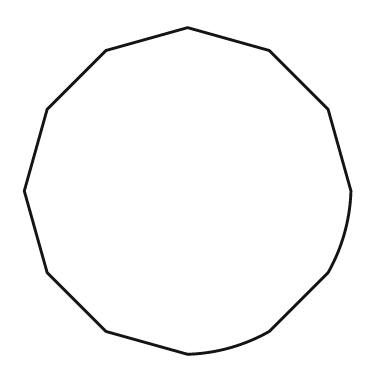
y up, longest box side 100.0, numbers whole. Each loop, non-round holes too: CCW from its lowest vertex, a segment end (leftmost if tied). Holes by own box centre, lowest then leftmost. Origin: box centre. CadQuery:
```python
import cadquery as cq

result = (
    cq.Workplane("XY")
    .moveTo(0.0, -50.0)
    .threePointArc((13.0, -48.0), (25.0, -43.0))
    .lineTo(43.0, -25.0)
    .threePointArc((48.0, -13.0), (50.0, 0.0))
    .lineTo(43.0, 25.0)
    .lineTo(25.0, 43.0)
    .lineTo(0.0, 50.0)
    .lineTo(-25.0, 43.0)
    .lineTo(-43.0, 25.0)
    .lineTo(-50.0, 0.0)
    .lineTo(-43.0, -25.0)
    .lineTo(-25.0, -43.0)
    .close()
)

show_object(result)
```